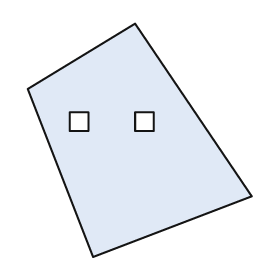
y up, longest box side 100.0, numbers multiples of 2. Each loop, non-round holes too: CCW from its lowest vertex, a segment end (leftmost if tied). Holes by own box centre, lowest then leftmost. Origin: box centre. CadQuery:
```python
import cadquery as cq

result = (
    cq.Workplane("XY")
    .moveTo(-20.0, -50.0)
    .lineTo(48.0, -24.0)
    .lineTo(-2.0, 50.0)
    .lineTo(-48.0, 22.0)
    .close()
    .moveTo(-30.0, 4.0)
    .lineTo(-22.0, 4.0)
    .lineTo(-22.0, 12.0)
    .lineTo(-30.0, 12.0)
    .close()
    .moveTo(-2.0, 4.0)
    .lineTo(6.0, 4.0)
    .lineTo(6.0, 12.0)
    .lineTo(-2.0, 12.0)
    .close()
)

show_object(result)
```